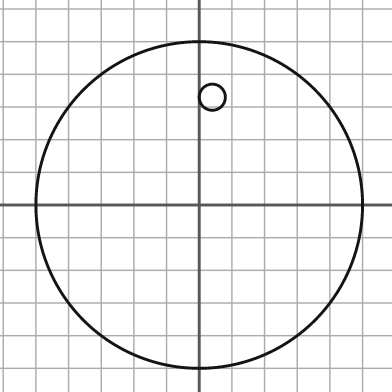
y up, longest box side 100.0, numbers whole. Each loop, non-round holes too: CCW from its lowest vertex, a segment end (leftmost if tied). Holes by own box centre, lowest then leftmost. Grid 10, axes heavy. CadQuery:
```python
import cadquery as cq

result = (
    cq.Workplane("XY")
    .moveTo(0.0, 0.0)
    .circle(50.0)
    .moveTo(4.0, 33.0)
    .circle(4.0)
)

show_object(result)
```